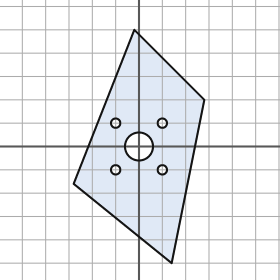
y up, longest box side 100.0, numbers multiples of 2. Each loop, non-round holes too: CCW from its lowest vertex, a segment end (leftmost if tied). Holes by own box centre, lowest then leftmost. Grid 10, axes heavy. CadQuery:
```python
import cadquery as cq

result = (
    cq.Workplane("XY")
    .moveTo(14.0, -50.0)
    .lineTo(28.0, 20.0)
    .lineTo(-2.0, 50.0)
    .lineTo(-28.0, -16.0)
    .close()
    .moveTo(-10.0, -10.0)
    .circle(2.0)
    .moveTo(10.0, -10.0)
    .circle(2.0)
    .moveTo(0.0, 0.0)
    .circle(6.0)
    .moveTo(-10.0, 10.0)
    .circle(2.0)
    .moveTo(10.0, 10.0)
    .circle(2.0)
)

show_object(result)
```